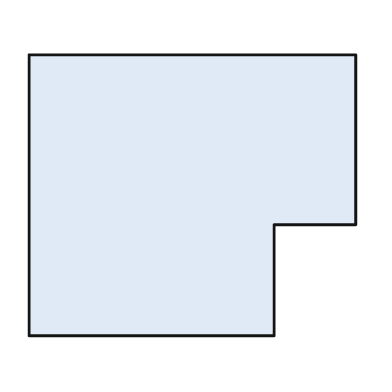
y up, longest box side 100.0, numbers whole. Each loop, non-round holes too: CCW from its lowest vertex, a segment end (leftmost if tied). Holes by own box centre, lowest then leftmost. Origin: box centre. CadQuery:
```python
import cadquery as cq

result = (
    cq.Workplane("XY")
    .moveTo(-50.0, -43.0)
    .lineTo(25.0, -43.0)
    .lineTo(25.0, -9.0)
    .lineTo(50.0, -9.0)
    .lineTo(50.0, 43.0)
    .lineTo(-50.0, 43.0)
    .close()
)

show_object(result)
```